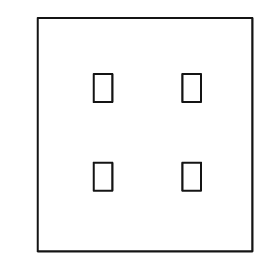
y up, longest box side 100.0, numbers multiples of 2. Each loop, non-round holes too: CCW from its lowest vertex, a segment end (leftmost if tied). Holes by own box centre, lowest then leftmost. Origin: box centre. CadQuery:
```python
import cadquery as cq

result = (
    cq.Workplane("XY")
    .moveTo(-46.0, -50.0)
    .lineTo(46.0, -50.0)
    .lineTo(46.0, 50.0)
    .lineTo(-46.0, 50.0)
    .close()
    .moveTo(-22.0, -24.0)
    .lineTo(-14.0, -24.0)
    .lineTo(-14.0, -12.0)
    .lineTo(-22.0, -12.0)
    .close()
    .moveTo(16.0, -24.0)
    .lineTo(24.0, -24.0)
    .lineTo(24.0, -12.0)
    .lineTo(16.0, -12.0)
    .close()
    .moveTo(-22.0, 14.0)
    .lineTo(-14.0, 14.0)
    .lineTo(-14.0, 26.0)
    .lineTo(-22.0, 26.0)
    .close()
    .moveTo(16.0, 14.0)
    .lineTo(24.0, 14.0)
    .lineTo(24.0, 26.0)
    .lineTo(16.0, 26.0)
    .close()
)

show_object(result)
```